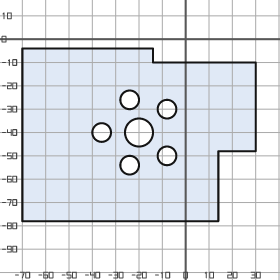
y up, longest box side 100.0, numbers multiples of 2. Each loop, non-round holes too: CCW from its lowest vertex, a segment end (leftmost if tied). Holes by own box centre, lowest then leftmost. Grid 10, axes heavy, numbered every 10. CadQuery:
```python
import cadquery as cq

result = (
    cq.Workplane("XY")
    .moveTo(-70.0, -78.0)
    .lineTo(14.0, -78.0)
    .lineTo(14.0, -48.0)
    .lineTo(30.0, -48.0)
    .lineTo(30.0, -10.0)
    .lineTo(-14.0, -10.0)
    .lineTo(-14.0, -4.0)
    .lineTo(-70.0, -4.0)
    .close()
    .moveTo(-24.0, -54.0)
    .circle(4.0)
    .moveTo(-8.0, -50.0)
    .circle(4.0)
    .moveTo(-36.0, -40.0)
    .circle(4.0)
    .moveTo(-20.0, -40.0)
    .circle(6.0)
    .moveTo(-8.0, -30.0)
    .circle(4.0)
    .moveTo(-24.0, -26.0)
    .circle(4.0)
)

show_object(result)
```